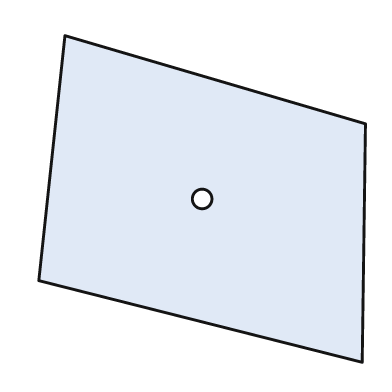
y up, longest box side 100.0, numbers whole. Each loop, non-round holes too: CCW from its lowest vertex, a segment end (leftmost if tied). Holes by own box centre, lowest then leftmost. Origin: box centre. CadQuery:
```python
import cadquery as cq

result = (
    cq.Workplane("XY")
    .moveTo(49.0, -50.0)
    .lineTo(50.0, 23.0)
    .lineTo(-42.0, 50.0)
    .lineTo(-50.0, -25.0)
    .close()
    .moveTo(0.0, 0.0)
    .circle(3.0)
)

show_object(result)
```